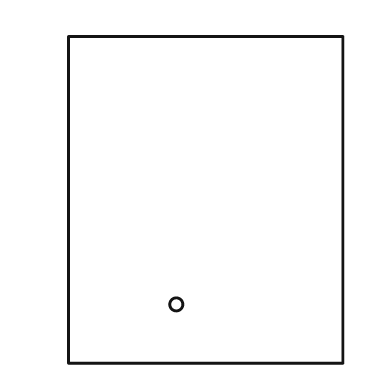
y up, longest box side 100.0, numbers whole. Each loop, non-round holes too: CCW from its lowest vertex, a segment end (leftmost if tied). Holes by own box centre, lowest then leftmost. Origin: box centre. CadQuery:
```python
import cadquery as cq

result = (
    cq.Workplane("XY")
    .moveTo(-42.0, -50.0)
    .lineTo(42.0, -50.0)
    .lineTo(42.0, 50.0)
    .lineTo(-42.0, 50.0)
    .close()
    .moveTo(-9.0, -32.0)
    .circle(2.0)
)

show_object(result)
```